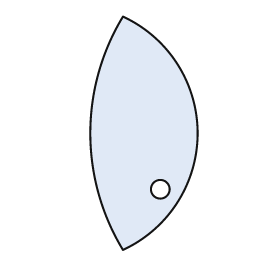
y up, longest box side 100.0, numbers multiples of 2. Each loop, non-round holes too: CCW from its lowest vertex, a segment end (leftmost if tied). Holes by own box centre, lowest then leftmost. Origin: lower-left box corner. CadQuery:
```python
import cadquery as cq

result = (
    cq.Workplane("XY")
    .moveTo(14.0, 0.0)
    .threePointArc((46.0, 50.0), (14.0, 100.0))
    .threePointArc((0.0, 50.0), (14.0, 0.0))
    .close()
    .moveTo(30.0, 26.0)
    .circle(4.0)
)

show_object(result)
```